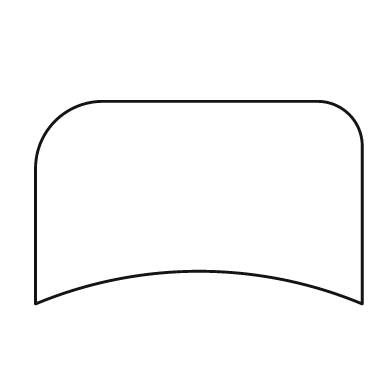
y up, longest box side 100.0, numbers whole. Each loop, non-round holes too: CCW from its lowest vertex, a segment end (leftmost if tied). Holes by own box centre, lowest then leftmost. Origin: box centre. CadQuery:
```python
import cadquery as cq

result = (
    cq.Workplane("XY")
    .moveTo(-50.0, -31.0)
    .threePointArc((0.0, -21.0), (50.0, -31.0))
    .lineTo(50.0, 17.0)
    .threePointArc((46.0, 27.0), (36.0, 31.0))
    .lineTo(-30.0, 31.0)
    .threePointArc((-44.0, 25.0), (-50.0, 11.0))
    .close()
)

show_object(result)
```